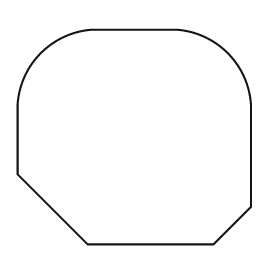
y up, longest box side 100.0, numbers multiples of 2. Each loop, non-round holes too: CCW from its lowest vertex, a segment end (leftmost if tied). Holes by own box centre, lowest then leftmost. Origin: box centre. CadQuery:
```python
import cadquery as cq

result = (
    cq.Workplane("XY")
    .moveTo(-20.0, -46.0)
    .lineTo(34.0, -46.0)
    .lineTo(50.0, -30.0)
    .lineTo(50.0, 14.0)
    .threePointArc((40.0, 36.0), (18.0, 46.0))
    .lineTo(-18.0, 46.0)
    .threePointArc((-40.0, 36.0), (-50.0, 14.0))
    .lineTo(-50.0, -16.0)
    .close()
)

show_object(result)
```